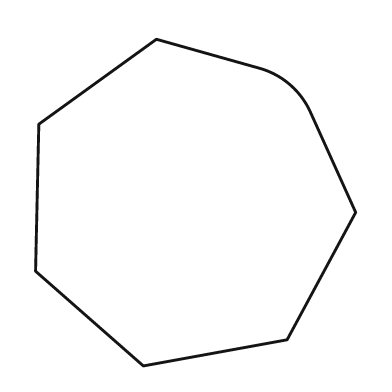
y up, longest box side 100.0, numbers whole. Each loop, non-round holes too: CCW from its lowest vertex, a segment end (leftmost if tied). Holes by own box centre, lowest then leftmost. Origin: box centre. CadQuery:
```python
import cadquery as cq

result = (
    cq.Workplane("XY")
    .moveTo(-16.0, -50.0)
    .lineTo(28.0, -42.0)
    .lineTo(49.0, -3.0)
    .lineTo(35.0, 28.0)
    .threePointArc((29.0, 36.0), (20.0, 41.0))
    .lineTo(-12.0, 50.0)
    .lineTo(-48.0, 24.0)
    .lineTo(-49.0, -21.0)
    .close()
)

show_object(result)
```